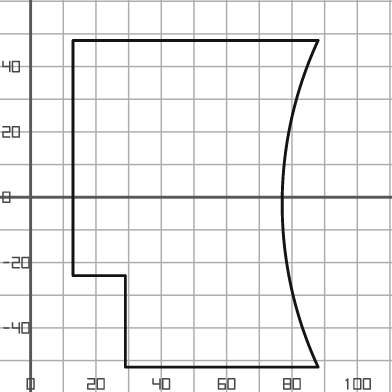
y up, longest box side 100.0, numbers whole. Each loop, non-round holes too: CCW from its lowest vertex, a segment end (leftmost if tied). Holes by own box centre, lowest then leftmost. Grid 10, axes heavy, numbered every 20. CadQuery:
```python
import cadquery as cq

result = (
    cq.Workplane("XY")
    .moveTo(29.0, -52.0)
    .lineTo(88.0, -52.0)
    .threePointArc((77.0, -2.0), (88.0, 48.0))
    .lineTo(13.0, 48.0)
    .lineTo(13.0, -24.0)
    .lineTo(29.0, -24.0)
    .close()
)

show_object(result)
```